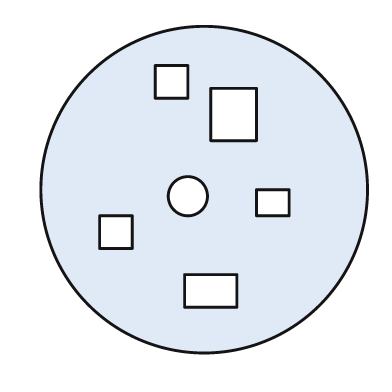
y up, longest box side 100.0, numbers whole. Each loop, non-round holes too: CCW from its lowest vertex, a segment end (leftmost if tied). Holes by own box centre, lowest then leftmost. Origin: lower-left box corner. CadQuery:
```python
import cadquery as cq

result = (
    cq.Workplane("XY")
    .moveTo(50.0, 50.0)
    .circle(50.0)
    .moveTo(44.0, 14.0)
    .lineTo(60.0, 14.0)
    .lineTo(60.0, 24.0)
    .lineTo(44.0, 24.0)
    .close()
    .moveTo(18.0, 32.0)
    .lineTo(28.0, 32.0)
    .lineTo(28.0, 42.0)
    .lineTo(18.0, 42.0)
    .close()
    .moveTo(66.0, 42.0)
    .lineTo(76.0, 42.0)
    .lineTo(76.0, 50.0)
    .lineTo(66.0, 50.0)
    .close()
    .moveTo(45.0, 48.0)
    .circle(6.0)
    .moveTo(52.0, 65.0)
    .lineTo(66.0, 65.0)
    .lineTo(66.0, 81.0)
    .lineTo(52.0, 81.0)
    .close()
    .moveTo(35.0, 78.0)
    .lineTo(45.0, 78.0)
    .lineTo(45.0, 88.0)
    .lineTo(35.0, 88.0)
    .close()
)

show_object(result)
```